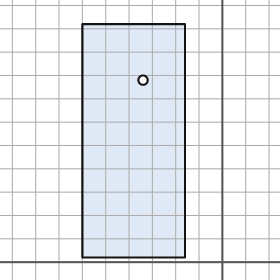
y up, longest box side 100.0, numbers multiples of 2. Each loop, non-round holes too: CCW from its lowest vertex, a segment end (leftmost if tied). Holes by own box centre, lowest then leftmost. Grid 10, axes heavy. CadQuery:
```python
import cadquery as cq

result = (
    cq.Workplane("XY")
    .moveTo(-60.0, 2.0)
    .lineTo(-16.0, 2.0)
    .lineTo(-16.0, 102.0)
    .lineTo(-60.0, 102.0)
    .close()
    .moveTo(-34.0, 78.0)
    .circle(2.0)
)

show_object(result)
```